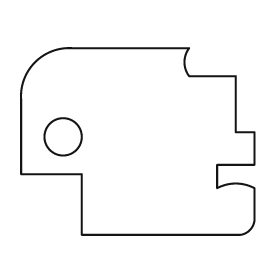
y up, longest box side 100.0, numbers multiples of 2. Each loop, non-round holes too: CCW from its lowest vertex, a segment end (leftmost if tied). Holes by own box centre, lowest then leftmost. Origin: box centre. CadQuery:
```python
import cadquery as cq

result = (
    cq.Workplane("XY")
    .moveTo(-24.0, -40.0)
    .lineTo(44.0, -40.0)
    .threePointArc((48.0, -38.0), (50.0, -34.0))
    .lineTo(50.0, -20.0)
    .threePointArc((42.0, -18.0), (34.0, -20.0))
    .lineTo(34.0, -10.0)
    .lineTo(50.0, -10.0)
    .lineTo(50.0, 4.0)
    .lineTo(42.0, 4.0)
    .lineTo(42.0, 28.0)
    .lineTo(22.0, 28.0)
    .threePointArc((20.0, 34.0), (22.0, 40.0))
    .lineTo(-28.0, 40.0)
    .threePointArc((-44.0, 34.0), (-50.0, 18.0))
    .lineTo(-50.0, -14.0)
    .lineTo(-24.0, -14.0)
    .close()
    .moveTo(-32.0, 2.0)
    .circle(8.0)
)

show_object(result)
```